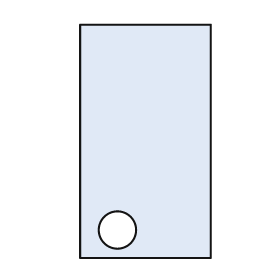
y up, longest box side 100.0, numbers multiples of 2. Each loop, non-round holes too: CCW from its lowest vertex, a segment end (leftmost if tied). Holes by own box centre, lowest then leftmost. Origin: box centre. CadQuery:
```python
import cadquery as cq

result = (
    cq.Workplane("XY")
    .moveTo(-28.0, -50.0)
    .lineTo(28.0, -50.0)
    .lineTo(28.0, 50.0)
    .lineTo(-28.0, 50.0)
    .close()
    .moveTo(-12.0, -38.0)
    .circle(8.0)
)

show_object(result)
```